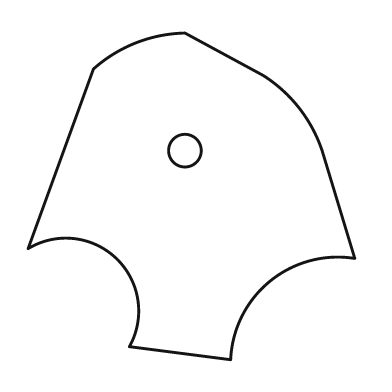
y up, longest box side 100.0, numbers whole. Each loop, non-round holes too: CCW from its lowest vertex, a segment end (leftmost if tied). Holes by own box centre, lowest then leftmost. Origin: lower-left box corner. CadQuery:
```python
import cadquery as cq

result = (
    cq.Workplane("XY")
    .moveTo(62.0, 0.0)
    .threePointArc((74.0, 24.0), (100.0, 31.0))
    .lineTo(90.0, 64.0)
    .threePointArc((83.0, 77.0), (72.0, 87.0))
    .lineTo(48.0, 100.0)
    .threePointArc((33.0, 97.0), (20.0, 89.0))
    .lineTo(0.0, 34.0)
    .threePointArc((27.0, 31.0), (31.0, 4.0))
    .close()
    .moveTo(48.0, 64.0)
    .circle(5.0)
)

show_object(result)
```